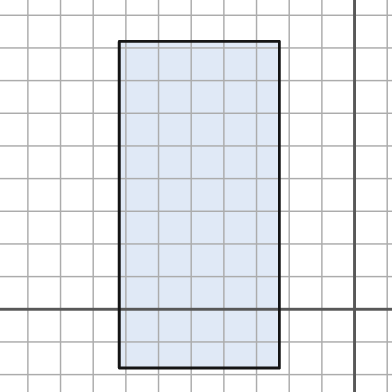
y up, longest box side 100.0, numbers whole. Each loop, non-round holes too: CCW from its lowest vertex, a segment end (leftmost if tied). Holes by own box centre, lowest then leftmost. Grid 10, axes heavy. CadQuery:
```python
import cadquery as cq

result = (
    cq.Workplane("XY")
    .moveTo(-72.0, -18.0)
    .lineTo(-23.0, -18.0)
    .lineTo(-23.0, 82.0)
    .lineTo(-72.0, 82.0)
    .close()
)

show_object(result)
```